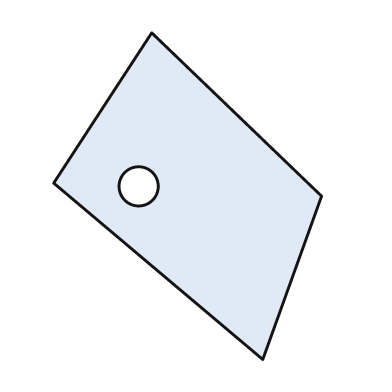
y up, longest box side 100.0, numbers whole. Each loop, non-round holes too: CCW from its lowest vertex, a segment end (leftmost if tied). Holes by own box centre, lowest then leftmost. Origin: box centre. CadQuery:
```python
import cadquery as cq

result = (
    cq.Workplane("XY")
    .moveTo(23.0, -50.0)
    .lineTo(41.0, 0.0)
    .lineTo(-11.0, 50.0)
    .lineTo(-41.0, 4.0)
    .close()
    .moveTo(-15.0, 3.0)
    .circle(6.0)
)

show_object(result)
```